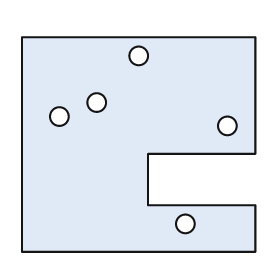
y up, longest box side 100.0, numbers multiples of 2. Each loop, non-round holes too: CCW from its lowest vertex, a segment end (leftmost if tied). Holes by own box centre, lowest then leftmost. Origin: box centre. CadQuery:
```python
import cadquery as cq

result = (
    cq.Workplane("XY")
    .moveTo(-50.0, -46.0)
    .lineTo(50.0, -46.0)
    .lineTo(50.0, -26.0)
    .lineTo(4.0, -26.0)
    .lineTo(4.0, -4.0)
    .lineTo(50.0, -4.0)
    .lineTo(50.0, 46.0)
    .lineTo(-50.0, 46.0)
    .close()
    .moveTo(20.0, -34.0)
    .circle(4.0)
    .moveTo(38.0, 8.0)
    .circle(4.0)
    .moveTo(-34.0, 12.0)
    .circle(4.0)
    .moveTo(-18.0, 18.0)
    .circle(4.0)
    .moveTo(0.0, 38.0)
    .circle(4.0)
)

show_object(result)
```